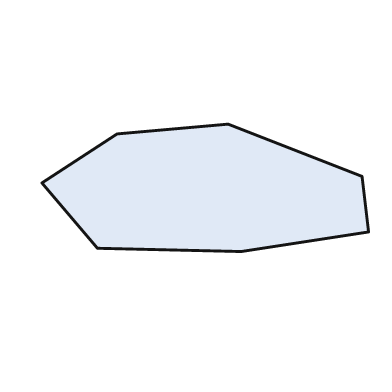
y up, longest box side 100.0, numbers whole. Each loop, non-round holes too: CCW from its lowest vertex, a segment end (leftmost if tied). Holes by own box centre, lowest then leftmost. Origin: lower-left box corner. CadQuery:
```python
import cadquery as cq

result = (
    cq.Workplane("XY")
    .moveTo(61.0, 0.0)
    .lineTo(100.0, 6.0)
    .lineTo(98.0, 23.0)
    .lineTo(57.0, 39.0)
    .lineTo(23.0, 36.0)
    .lineTo(0.0, 21.0)
    .lineTo(17.0, 1.0)
    .close()
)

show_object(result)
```